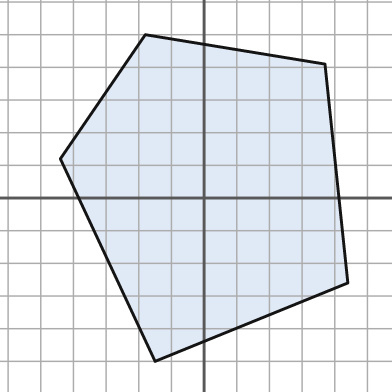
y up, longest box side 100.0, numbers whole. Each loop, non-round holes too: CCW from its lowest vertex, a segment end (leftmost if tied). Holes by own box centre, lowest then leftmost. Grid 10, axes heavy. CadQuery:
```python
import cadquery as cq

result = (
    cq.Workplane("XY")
    .moveTo(-15.0, -50.0)
    .lineTo(44.0, -26.0)
    .lineTo(37.0, 41.0)
    .lineTo(-18.0, 50.0)
    .lineTo(-44.0, 12.0)
    .close()
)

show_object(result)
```